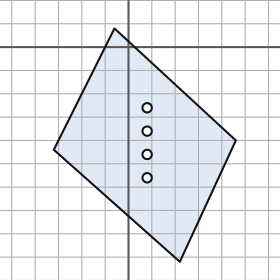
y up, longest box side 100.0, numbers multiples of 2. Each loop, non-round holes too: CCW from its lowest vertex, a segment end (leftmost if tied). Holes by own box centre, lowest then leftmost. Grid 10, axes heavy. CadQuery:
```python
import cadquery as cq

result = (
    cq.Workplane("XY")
    .moveTo(22.0, -92.0)
    .lineTo(46.0, -40.0)
    .lineTo(-6.0, 8.0)
    .lineTo(-32.0, -44.0)
    .close()
    .moveTo(8.0, -56.0)
    .circle(2.0)
    .moveTo(8.0, -46.0)
    .circle(2.0)
    .moveTo(8.0, -36.0)
    .circle(2.0)
    .moveTo(8.0, -26.0)
    .circle(2.0)
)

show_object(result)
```